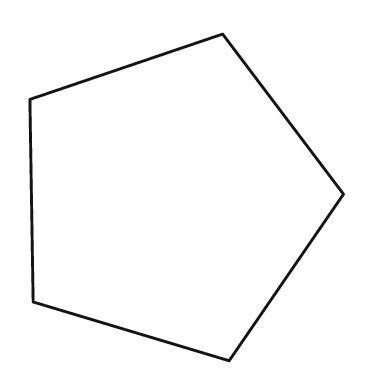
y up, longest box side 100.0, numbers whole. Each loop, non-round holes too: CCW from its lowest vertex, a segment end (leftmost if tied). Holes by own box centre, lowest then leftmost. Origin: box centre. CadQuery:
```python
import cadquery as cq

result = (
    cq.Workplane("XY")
    .moveTo(13.0, -50.0)
    .lineTo(48.0, 1.0)
    .lineTo(11.0, 50.0)
    .lineTo(-48.0, 30.0)
    .lineTo(-47.0, -32.0)
    .close()
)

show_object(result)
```